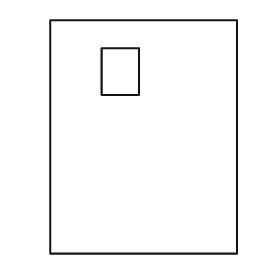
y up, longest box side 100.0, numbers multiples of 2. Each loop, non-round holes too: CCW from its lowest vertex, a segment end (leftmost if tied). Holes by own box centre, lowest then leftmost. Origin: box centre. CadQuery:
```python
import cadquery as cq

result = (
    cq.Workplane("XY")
    .moveTo(-40.0, -50.0)
    .lineTo(40.0, -50.0)
    .lineTo(40.0, 50.0)
    .lineTo(-40.0, 50.0)
    .close()
    .moveTo(-18.0, 18.0)
    .lineTo(-2.0, 18.0)
    .lineTo(-2.0, 38.0)
    .lineTo(-18.0, 38.0)
    .close()
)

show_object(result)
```